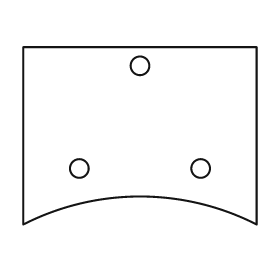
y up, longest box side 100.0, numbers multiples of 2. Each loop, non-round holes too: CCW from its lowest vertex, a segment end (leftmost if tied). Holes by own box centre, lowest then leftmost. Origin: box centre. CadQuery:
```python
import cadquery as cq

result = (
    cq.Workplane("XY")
    .moveTo(-50.0, -38.0)
    .threePointArc((0.0, -26.0), (50.0, -38.0))
    .lineTo(50.0, 38.0)
    .lineTo(-50.0, 38.0)
    .close()
    .moveTo(-26.0, -14.0)
    .circle(4.0)
    .moveTo(26.0, -14.0)
    .circle(4.0)
    .moveTo(0.0, 30.0)
    .circle(4.0)
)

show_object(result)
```